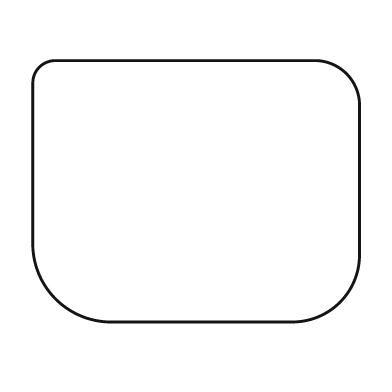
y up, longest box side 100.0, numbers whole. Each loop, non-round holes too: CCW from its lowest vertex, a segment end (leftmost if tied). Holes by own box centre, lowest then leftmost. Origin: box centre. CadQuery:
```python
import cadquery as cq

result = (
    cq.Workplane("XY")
    .moveTo(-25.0, -40.0)
    .lineTo(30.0, -40.0)
    .threePointArc((44.0, -34.0), (50.0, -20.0))
    .lineTo(50.0, 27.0)
    .threePointArc((46.0, 36.0), (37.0, 40.0))
    .lineTo(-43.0, 40.0)
    .threePointArc((-48.0, 38.0), (-50.0, 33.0))
    .lineTo(-50.0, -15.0)
    .threePointArc((-43.0, -33.0), (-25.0, -40.0))
    .close()
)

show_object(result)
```